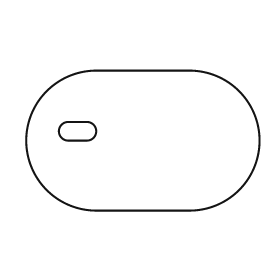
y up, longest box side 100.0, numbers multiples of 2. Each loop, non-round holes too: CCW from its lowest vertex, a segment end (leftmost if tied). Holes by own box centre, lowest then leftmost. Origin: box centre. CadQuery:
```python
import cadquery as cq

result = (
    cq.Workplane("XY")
    .moveTo(-20.0, -30.0)
    .lineTo(20.0, -30.0)
    .threePointArc((50.0, 0.0), (20.0, 30.0))
    .lineTo(-20.0, 30.0)
    .threePointArc((-50.0, 0.0), (-20.0, -30.0))
    .close()
    .moveTo(-32.0, 0.0)
    .lineTo(-24.0, 0.0)
    .threePointArc((-20.0, 4.0), (-24.0, 8.0))
    .lineTo(-32.0, 8.0)
    .threePointArc((-36.0, 4.0), (-32.0, 0.0))
    .close()
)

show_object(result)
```